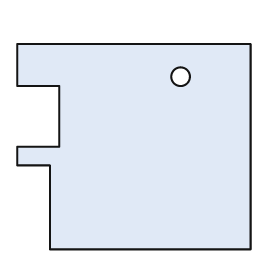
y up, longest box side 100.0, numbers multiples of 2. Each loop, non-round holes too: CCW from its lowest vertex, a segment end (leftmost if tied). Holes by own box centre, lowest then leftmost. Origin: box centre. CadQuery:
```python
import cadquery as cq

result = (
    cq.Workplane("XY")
    .moveTo(-36.0, -44.0)
    .lineTo(50.0, -44.0)
    .lineTo(50.0, 44.0)
    .lineTo(-50.0, 44.0)
    .lineTo(-50.0, 26.0)
    .lineTo(-32.0, 26.0)
    .lineTo(-32.0, 0.0)
    .lineTo(-50.0, 0.0)
    .lineTo(-50.0, -8.0)
    .lineTo(-36.0, -8.0)
    .close()
    .moveTo(20.0, 30.0)
    .circle(4.0)
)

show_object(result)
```